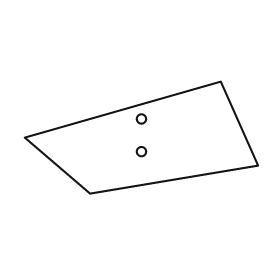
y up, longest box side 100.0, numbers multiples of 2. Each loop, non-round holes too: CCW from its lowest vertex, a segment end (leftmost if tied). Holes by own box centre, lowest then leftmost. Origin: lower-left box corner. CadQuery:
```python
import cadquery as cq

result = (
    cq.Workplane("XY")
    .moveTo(28.0, 0.0)
    .lineTo(100.0, 12.0)
    .lineTo(84.0, 48.0)
    .lineTo(0.0, 24.0)
    .close()
    .moveTo(50.0, 18.0)
    .circle(2.0)
    .moveTo(50.0, 32.0)
    .circle(2.0)
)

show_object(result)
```